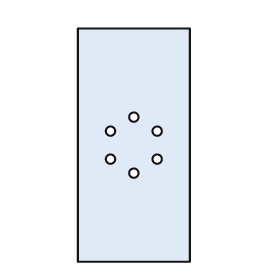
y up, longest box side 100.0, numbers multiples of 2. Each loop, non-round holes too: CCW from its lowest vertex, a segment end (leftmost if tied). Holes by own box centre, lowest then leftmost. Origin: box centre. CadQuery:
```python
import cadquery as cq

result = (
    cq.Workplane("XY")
    .moveTo(-24.0, -50.0)
    .lineTo(24.0, -50.0)
    .lineTo(24.0, 50.0)
    .lineTo(-24.0, 50.0)
    .close()
    .moveTo(0.0, -12.0)
    .circle(2.0)
    .moveTo(-10.0, -6.0)
    .circle(2.0)
    .moveTo(10.0, -6.0)
    .circle(2.0)
    .moveTo(-10.0, 6.0)
    .circle(2.0)
    .moveTo(10.0, 6.0)
    .circle(2.0)
    .moveTo(0.0, 12.0)
    .circle(2.0)
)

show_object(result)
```